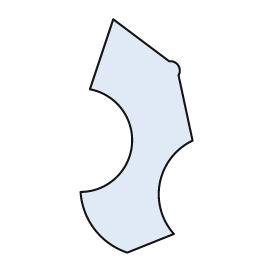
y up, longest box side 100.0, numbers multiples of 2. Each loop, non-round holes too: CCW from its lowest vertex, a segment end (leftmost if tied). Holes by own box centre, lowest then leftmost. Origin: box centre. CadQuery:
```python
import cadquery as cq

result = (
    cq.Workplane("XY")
    .moveTo(-4.0, -50.0)
    .lineTo(16.0, -42.0)
    .threePointArc((10.0, -20.0), (24.0, -2.0))
    .lineTo(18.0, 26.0)
    .threePointArc((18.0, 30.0), (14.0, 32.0))
    .lineTo(-10.0, 50.0)
    .lineTo(-20.0, 20.0)
    .threePointArc((-2.0, -4.0), (-24.0, -24.0))
    .threePointArc((-18.0, -40.0), (-4.0, -50.0))
    .close()
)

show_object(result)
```